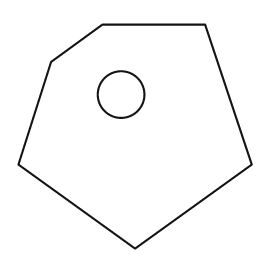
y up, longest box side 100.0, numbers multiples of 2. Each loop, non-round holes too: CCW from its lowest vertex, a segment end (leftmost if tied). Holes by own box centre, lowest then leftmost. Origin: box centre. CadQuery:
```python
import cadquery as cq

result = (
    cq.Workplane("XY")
    .moveTo(0.0, -48.0)
    .lineTo(50.0, -12.0)
    .lineTo(30.0, 48.0)
    .lineTo(-14.0, 48.0)
    .lineTo(-36.0, 32.0)
    .lineTo(-50.0, -12.0)
    .close()
    .moveTo(-6.0, 18.0)
    .circle(10.0)
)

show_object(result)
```